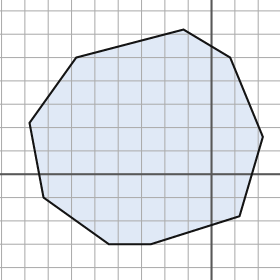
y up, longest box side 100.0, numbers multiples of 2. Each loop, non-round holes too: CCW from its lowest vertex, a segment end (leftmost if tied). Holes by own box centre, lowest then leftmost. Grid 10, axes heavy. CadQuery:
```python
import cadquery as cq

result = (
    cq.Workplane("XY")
    .moveTo(-44.0, -30.0)
    .lineTo(-26.0, -30.0)
    .lineTo(12.0, -18.0)
    .lineTo(22.0, 16.0)
    .lineTo(8.0, 50.0)
    .lineTo(-12.0, 62.0)
    .lineTo(-58.0, 50.0)
    .lineTo(-78.0, 22.0)
    .lineTo(-72.0, -10.0)
    .close()
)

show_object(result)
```